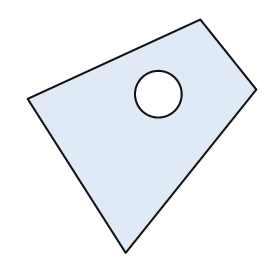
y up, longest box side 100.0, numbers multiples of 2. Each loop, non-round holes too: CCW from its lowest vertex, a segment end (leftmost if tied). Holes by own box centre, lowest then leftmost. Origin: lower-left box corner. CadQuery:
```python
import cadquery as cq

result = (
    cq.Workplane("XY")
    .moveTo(42.0, 0.0)
    .lineTo(98.0, 70.0)
    .lineTo(74.0, 100.0)
    .lineTo(0.0, 66.0)
    .close()
    .moveTo(56.0, 68.0)
    .circle(10.0)
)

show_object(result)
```